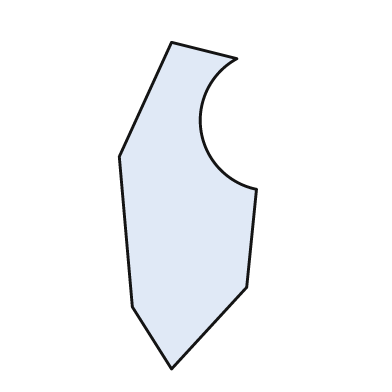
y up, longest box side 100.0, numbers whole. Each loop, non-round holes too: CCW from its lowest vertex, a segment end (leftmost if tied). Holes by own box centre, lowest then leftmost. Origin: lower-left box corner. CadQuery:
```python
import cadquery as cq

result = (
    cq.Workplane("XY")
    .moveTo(16.0, 0.0)
    .lineTo(39.0, 25.0)
    .lineTo(42.0, 55.0)
    .threePointArc((25.0, 73.0), (36.0, 95.0))
    .lineTo(16.0, 100.0)
    .lineTo(0.0, 65.0)
    .lineTo(4.0, 19.0)
    .close()
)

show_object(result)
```